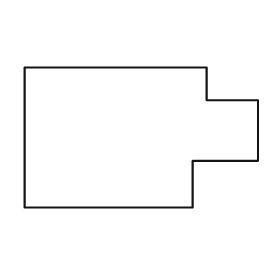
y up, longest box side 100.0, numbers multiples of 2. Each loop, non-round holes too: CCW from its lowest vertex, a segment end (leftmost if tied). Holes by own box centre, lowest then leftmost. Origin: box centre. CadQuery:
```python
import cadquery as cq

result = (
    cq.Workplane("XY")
    .moveTo(-50.0, -30.0)
    .lineTo(22.0, -30.0)
    .lineTo(22.0, -10.0)
    .lineTo(50.0, -10.0)
    .lineTo(50.0, 16.0)
    .lineTo(28.0, 16.0)
    .lineTo(28.0, 30.0)
    .lineTo(-50.0, 30.0)
    .close()
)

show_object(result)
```